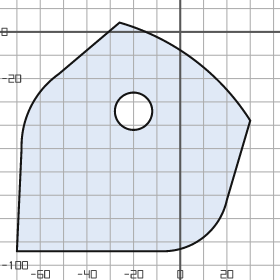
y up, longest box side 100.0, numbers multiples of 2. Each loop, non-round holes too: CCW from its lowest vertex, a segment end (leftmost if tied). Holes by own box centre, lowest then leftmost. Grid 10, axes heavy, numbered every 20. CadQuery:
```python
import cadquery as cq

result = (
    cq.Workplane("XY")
    .moveTo(-70.0, -94.0)
    .lineTo(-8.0, -94.0)
    .threePointArc((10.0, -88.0), (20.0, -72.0))
    .lineTo(30.0, -38.0)
    .threePointArc((6.0, -12.0), (-26.0, 4.0))
    .lineTo(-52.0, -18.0)
    .threePointArc((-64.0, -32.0), (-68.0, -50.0))
    .close()
    .moveTo(-20.0, -34.0)
    .circle(8.0)
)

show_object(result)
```